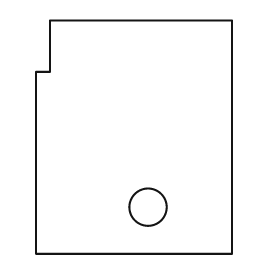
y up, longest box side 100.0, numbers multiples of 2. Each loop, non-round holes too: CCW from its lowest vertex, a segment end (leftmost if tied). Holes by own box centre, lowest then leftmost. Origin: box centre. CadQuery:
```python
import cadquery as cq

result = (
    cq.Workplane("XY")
    .moveTo(-42.0, -50.0)
    .lineTo(42.0, -50.0)
    .lineTo(42.0, 50.0)
    .lineTo(-36.0, 50.0)
    .lineTo(-36.0, 28.0)
    .lineTo(-42.0, 28.0)
    .close()
    .moveTo(6.0, -30.0)
    .circle(8.0)
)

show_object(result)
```